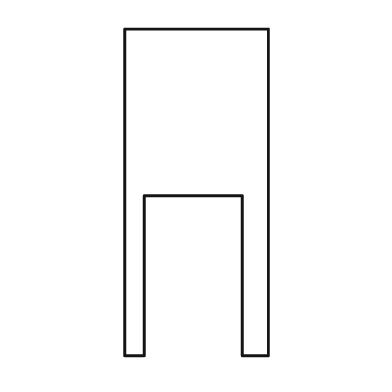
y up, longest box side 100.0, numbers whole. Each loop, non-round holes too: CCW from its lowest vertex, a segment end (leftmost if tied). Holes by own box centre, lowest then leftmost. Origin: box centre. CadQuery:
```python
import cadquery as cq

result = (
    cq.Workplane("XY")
    .moveTo(-22.0, -50.0)
    .lineTo(-16.0, -50.0)
    .lineTo(-16.0, -1.0)
    .lineTo(14.0, -1.0)
    .lineTo(14.0, -50.0)
    .lineTo(22.0, -50.0)
    .lineTo(22.0, 50.0)
    .lineTo(-22.0, 50.0)
    .close()
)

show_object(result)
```